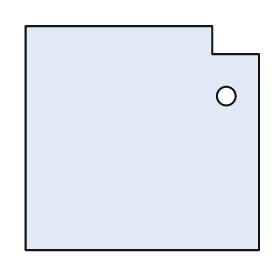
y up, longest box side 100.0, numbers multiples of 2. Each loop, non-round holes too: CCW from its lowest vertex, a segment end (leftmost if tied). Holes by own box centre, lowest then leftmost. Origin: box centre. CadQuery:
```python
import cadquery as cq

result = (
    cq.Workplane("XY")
    .moveTo(-50.0, -48.0)
    .lineTo(50.0, -48.0)
    .lineTo(50.0, 36.0)
    .lineTo(30.0, 36.0)
    .lineTo(30.0, 48.0)
    .lineTo(-50.0, 48.0)
    .close()
    .moveTo(36.0, 18.0)
    .circle(4.0)
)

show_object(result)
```